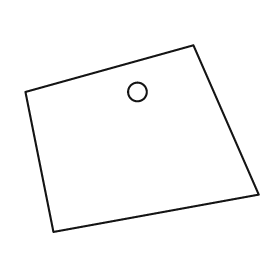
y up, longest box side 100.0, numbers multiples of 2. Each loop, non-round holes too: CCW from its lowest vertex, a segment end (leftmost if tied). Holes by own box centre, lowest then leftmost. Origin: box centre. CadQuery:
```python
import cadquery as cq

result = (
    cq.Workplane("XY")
    .moveTo(-38.0, -40.0)
    .lineTo(50.0, -24.0)
    .lineTo(22.0, 40.0)
    .lineTo(-50.0, 20.0)
    .close()
    .moveTo(-2.0, 20.0)
    .circle(4.0)
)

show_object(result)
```